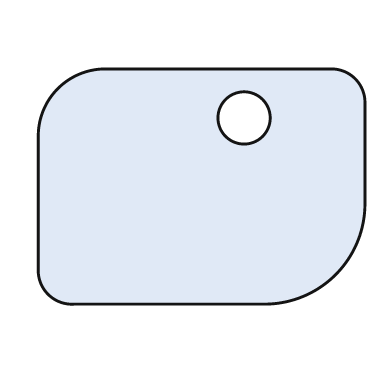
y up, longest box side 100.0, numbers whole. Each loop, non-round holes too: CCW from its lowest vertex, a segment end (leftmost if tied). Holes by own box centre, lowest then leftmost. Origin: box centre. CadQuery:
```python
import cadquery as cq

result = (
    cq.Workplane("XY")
    .moveTo(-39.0, -36.0)
    .lineTo(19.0, -36.0)
    .threePointArc((41.0, -27.0), (50.0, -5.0))
    .lineTo(50.0, 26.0)
    .threePointArc((47.0, 33.0), (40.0, 36.0))
    .lineTo(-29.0, 36.0)
    .threePointArc((-44.0, 30.0), (-50.0, 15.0))
    .lineTo(-50.0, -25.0)
    .threePointArc((-47.0, -33.0), (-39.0, -36.0))
    .close()
    .moveTo(13.0, 21.0)
    .circle(8.0)
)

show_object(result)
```